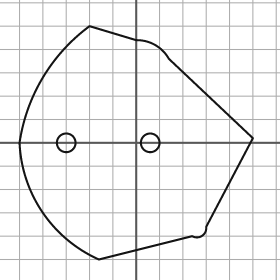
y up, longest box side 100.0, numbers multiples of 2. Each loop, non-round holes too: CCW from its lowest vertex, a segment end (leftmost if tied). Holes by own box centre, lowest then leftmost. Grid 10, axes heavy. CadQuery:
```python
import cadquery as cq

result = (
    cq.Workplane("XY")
    .moveTo(-16.0, -50.0)
    .lineTo(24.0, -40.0)
    .threePointArc((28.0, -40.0), (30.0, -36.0))
    .lineTo(50.0, 2.0)
    .lineTo(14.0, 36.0)
    .threePointArc((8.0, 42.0), (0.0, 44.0))
    .lineTo(-20.0, 50.0)
    .threePointArc((-40.0, 28.0), (-50.0, 0.0))
    .threePointArc((-40.0, -30.0), (-16.0, -50.0))
    .close()
    .moveTo(-30.0, 0.0)
    .circle(4.0)
    .moveTo(6.0, 0.0)
    .circle(4.0)
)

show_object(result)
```